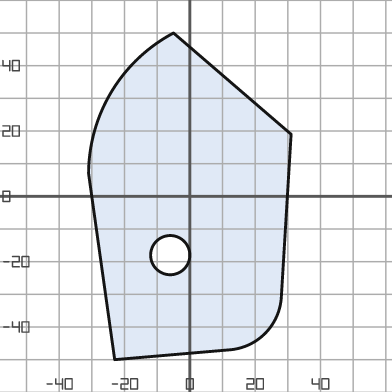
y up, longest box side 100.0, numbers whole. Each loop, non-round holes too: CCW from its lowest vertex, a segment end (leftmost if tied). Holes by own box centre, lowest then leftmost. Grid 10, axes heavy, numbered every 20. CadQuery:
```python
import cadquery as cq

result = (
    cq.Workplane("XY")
    .moveTo(-23.0, -50.0)
    .lineTo(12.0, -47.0)
    .threePointArc((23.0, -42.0), (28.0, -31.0))
    .lineTo(31.0, 19.0)
    .lineTo(-5.0, 50.0)
    .threePointArc((-24.0, 32.0), (-31.0, 7.0))
    .close()
    .moveTo(-6.0, -18.0)
    .circle(6.0)
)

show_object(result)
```